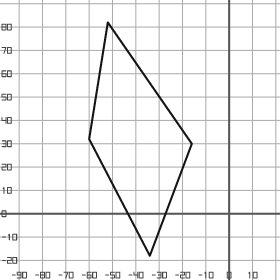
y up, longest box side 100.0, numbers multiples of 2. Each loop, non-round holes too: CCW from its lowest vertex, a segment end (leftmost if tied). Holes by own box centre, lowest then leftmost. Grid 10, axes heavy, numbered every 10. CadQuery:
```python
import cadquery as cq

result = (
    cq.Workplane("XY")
    .moveTo(-34.0, -18.0)
    .lineTo(-16.0, 30.0)
    .lineTo(-52.0, 82.0)
    .lineTo(-60.0, 32.0)
    .close()
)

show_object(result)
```